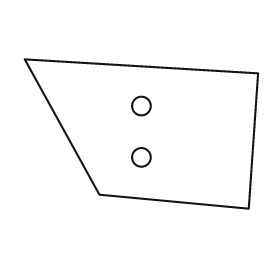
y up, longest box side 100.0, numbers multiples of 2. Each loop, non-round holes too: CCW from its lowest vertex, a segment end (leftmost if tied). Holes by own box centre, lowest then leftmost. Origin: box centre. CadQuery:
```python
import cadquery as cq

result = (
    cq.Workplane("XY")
    .moveTo(46.0, -32.0)
    .lineTo(50.0, 26.0)
    .lineTo(-50.0, 32.0)
    .lineTo(-18.0, -26.0)
    .close()
    .moveTo(0.0, -10.0)
    .circle(4.0)
    .moveTo(0.0, 12.0)
    .circle(4.0)
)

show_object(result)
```